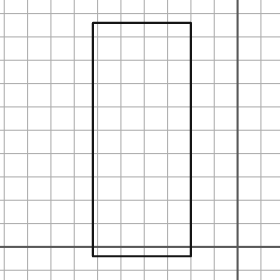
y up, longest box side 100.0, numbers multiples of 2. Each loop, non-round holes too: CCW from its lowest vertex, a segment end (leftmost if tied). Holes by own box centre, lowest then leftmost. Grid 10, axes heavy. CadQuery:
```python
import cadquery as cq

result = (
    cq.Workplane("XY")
    .moveTo(-62.0, -4.0)
    .lineTo(-20.0, -4.0)
    .lineTo(-20.0, 96.0)
    .lineTo(-62.0, 96.0)
    .close()
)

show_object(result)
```